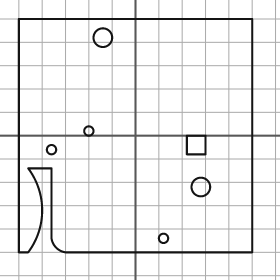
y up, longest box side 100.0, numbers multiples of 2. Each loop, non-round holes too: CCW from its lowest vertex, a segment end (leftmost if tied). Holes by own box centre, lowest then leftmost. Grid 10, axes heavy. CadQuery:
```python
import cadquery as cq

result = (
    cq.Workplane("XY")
    .moveTo(-50.0, -50.0)
    .lineTo(-46.0, -50.0)
    .threePointArc((-40.0, -32.0), (-46.0, -14.0))
    .lineTo(-36.0, -14.0)
    .lineTo(-36.0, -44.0)
    .threePointArc((-34.0, -48.0), (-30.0, -50.0))
    .lineTo(50.0, -50.0)
    .lineTo(50.0, 50.0)
    .lineTo(-50.0, 50.0)
    .close()
    .moveTo(12.0, -44.0)
    .circle(2.0)
    .moveTo(28.0, -22.0)
    .circle(4.0)
    .moveTo(-36.0, -6.0)
    .circle(2.0)
    .moveTo(22.0, -8.0)
    .lineTo(30.0, -8.0)
    .lineTo(30.0, 0.0)
    .lineTo(22.0, 0.0)
    .close()
    .moveTo(-20.0, 2.0)
    .circle(2.0)
    .moveTo(-14.0, 42.0)
    .circle(4.0)
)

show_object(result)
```